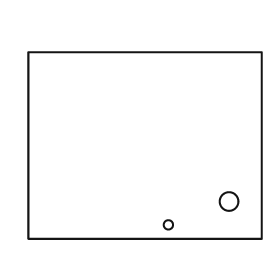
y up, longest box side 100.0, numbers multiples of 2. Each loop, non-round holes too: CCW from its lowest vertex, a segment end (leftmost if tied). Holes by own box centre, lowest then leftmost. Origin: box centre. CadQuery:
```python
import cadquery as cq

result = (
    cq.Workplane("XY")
    .moveTo(-50.0, -40.0)
    .lineTo(50.0, -40.0)
    .lineTo(50.0, 40.0)
    .lineTo(-50.0, 40.0)
    .close()
    .moveTo(10.0, -34.0)
    .circle(2.0)
    .moveTo(36.0, -24.0)
    .circle(4.0)
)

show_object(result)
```